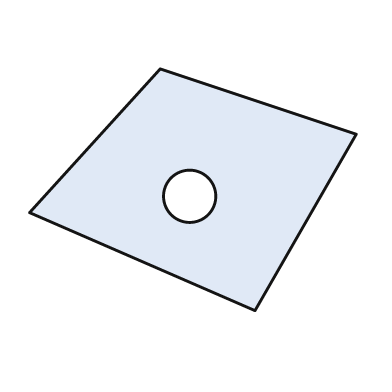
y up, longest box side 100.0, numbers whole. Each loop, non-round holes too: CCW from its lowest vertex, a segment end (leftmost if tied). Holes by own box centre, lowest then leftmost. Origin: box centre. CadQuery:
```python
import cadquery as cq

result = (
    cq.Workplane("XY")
    .moveTo(19.0, -37.0)
    .lineTo(50.0, 17.0)
    .lineTo(-10.0, 37.0)
    .lineTo(-50.0, -7.0)
    .close()
    .moveTo(-1.0, -2.0)
    .circle(8.0)
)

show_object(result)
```